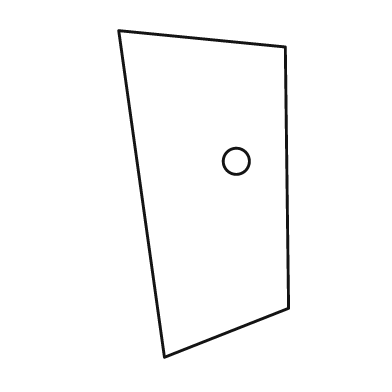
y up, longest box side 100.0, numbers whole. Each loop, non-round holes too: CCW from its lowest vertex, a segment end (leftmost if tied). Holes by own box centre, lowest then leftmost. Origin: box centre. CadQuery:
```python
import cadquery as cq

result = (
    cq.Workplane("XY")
    .moveTo(-12.0, -50.0)
    .lineTo(26.0, -35.0)
    .lineTo(25.0, 45.0)
    .lineTo(-26.0, 50.0)
    .close()
    .moveTo(10.0, 10.0)
    .circle(4.0)
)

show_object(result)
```